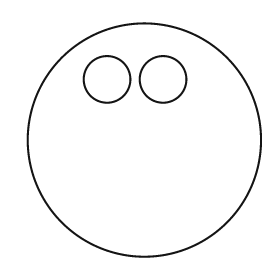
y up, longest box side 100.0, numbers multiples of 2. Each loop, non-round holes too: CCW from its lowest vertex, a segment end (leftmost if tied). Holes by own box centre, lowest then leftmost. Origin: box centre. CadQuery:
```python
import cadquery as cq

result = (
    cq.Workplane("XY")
    .moveTo(0.0, 0.0)
    .circle(50.0)
    .moveTo(-16.0, 26.0)
    .circle(10.0)
    .moveTo(8.0, 26.0)
    .circle(10.0)
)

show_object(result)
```